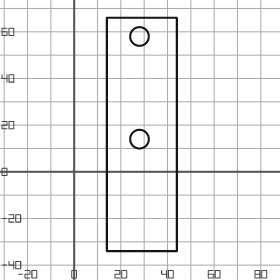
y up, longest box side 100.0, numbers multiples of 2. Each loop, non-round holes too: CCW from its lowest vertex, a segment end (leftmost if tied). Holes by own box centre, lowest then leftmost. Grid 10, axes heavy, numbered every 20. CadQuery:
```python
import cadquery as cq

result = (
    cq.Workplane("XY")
    .moveTo(14.0, -34.0)
    .lineTo(44.0, -34.0)
    .lineTo(44.0, 66.0)
    .lineTo(14.0, 66.0)
    .close()
    .moveTo(28.0, 14.0)
    .circle(4.0)
    .moveTo(28.0, 58.0)
    .circle(4.0)
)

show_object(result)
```